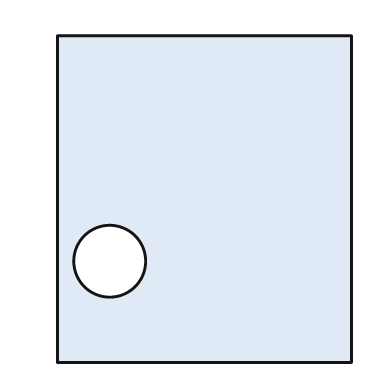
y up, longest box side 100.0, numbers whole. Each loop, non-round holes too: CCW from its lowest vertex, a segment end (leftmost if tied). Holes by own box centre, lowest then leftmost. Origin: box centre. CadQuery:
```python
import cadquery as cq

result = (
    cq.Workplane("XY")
    .moveTo(-45.0, -50.0)
    .lineTo(45.0, -50.0)
    .lineTo(45.0, 50.0)
    .lineTo(-45.0, 50.0)
    .close()
    .moveTo(-29.0, -19.0)
    .circle(11.0)
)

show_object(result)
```